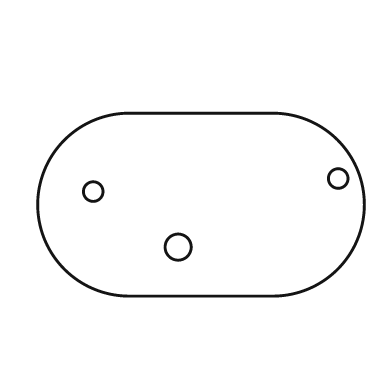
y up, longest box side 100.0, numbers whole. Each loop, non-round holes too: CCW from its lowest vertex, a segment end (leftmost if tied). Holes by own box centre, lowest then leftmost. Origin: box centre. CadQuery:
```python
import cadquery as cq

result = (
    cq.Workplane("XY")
    .moveTo(-22.0, -28.0)
    .lineTo(22.0, -28.0)
    .threePointArc((50.0, 0.0), (22.0, 28.0))
    .lineTo(-22.0, 28.0)
    .threePointArc((-50.0, 0.0), (-22.0, -28.0))
    .close()
    .moveTo(-7.0, -13.0)
    .circle(4.0)
    .moveTo(-33.0, 4.0)
    .circle(3.0)
    .moveTo(42.0, 8.0)
    .circle(3.0)
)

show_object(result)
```